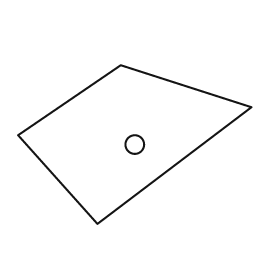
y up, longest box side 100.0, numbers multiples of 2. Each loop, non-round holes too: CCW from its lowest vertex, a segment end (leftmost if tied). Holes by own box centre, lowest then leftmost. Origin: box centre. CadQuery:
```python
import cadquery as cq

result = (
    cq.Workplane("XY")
    .moveTo(-16.0, -34.0)
    .lineTo(50.0, 16.0)
    .lineTo(-6.0, 34.0)
    .lineTo(-50.0, 4.0)
    .close()
    .moveTo(0.0, 0.0)
    .circle(4.0)
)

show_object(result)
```